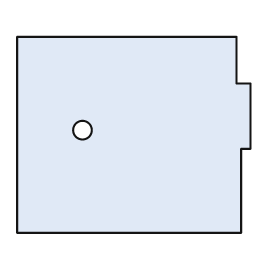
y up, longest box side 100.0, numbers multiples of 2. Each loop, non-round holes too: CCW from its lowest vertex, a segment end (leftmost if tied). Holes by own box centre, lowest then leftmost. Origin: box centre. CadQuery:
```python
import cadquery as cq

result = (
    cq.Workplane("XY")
    .moveTo(-50.0, -42.0)
    .lineTo(46.0, -42.0)
    .lineTo(46.0, -6.0)
    .lineTo(50.0, -6.0)
    .lineTo(50.0, 22.0)
    .lineTo(44.0, 22.0)
    .lineTo(44.0, 42.0)
    .lineTo(-50.0, 42.0)
    .close()
    .moveTo(-22.0, 2.0)
    .circle(4.0)
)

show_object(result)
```